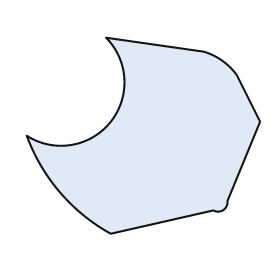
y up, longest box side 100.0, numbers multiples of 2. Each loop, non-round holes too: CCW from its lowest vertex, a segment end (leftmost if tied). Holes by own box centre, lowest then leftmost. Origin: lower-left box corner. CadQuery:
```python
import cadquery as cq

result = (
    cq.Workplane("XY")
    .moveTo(36.0, 0.0)
    .lineTo(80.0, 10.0)
    .threePointArc((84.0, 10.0), (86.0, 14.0))
    .lineTo(100.0, 48.0)
    .lineTo(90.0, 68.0)
    .threePointArc((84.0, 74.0), (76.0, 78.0))
    .lineTo(34.0, 84.0)
    .threePointArc((36.0, 48.0), (0.0, 42.0))
    .threePointArc((14.0, 18.0), (36.0, 0.0))
    .close()
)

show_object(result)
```